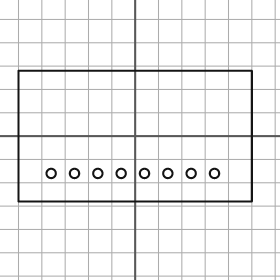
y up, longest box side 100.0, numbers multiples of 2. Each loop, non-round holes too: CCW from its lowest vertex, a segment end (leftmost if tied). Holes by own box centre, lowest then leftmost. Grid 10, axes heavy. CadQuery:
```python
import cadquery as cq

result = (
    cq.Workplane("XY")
    .moveTo(-50.0, -28.0)
    .lineTo(50.0, -28.0)
    .lineTo(50.0, 28.0)
    .lineTo(-50.0, 28.0)
    .close()
    .moveTo(-36.0, -16.0)
    .circle(2.0)
    .moveTo(-26.0, -16.0)
    .circle(2.0)
    .moveTo(-16.0, -16.0)
    .circle(2.0)
    .moveTo(-6.0, -16.0)
    .circle(2.0)
    .moveTo(4.0, -16.0)
    .circle(2.0)
    .moveTo(14.0, -16.0)
    .circle(2.0)
    .moveTo(24.0, -16.0)
    .circle(2.0)
    .moveTo(34.0, -16.0)
    .circle(2.0)
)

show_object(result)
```